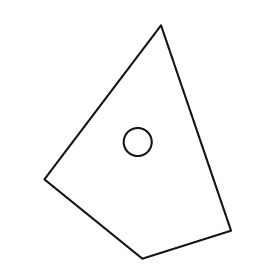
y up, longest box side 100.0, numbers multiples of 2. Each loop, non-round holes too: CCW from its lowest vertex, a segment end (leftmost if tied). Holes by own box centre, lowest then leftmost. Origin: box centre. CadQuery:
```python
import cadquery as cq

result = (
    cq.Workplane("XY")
    .moveTo(2.0, -50.0)
    .lineTo(40.0, -38.0)
    .lineTo(10.0, 50.0)
    .lineTo(-40.0, -16.0)
    .close()
    .moveTo(0.0, 0.0)
    .circle(6.0)
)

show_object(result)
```